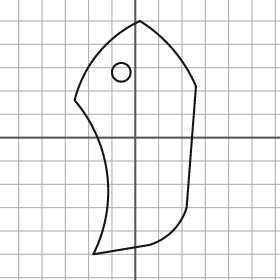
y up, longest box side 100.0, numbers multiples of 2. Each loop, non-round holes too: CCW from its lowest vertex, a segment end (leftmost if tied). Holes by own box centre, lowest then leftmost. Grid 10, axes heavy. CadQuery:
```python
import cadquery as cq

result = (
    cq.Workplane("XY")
    .moveTo(-18.0, -50.0)
    .lineTo(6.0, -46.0)
    .threePointArc((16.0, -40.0), (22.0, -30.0))
    .lineTo(26.0, 22.0)
    .threePointArc((16.0, 38.0), (2.0, 50.0))
    .threePointArc((-16.0, 36.0), (-26.0, 16.0))
    .threePointArc((-12.0, -16.0), (-18.0, -50.0))
    .close()
    .moveTo(-6.0, 28.0)
    .circle(4.0)
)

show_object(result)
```